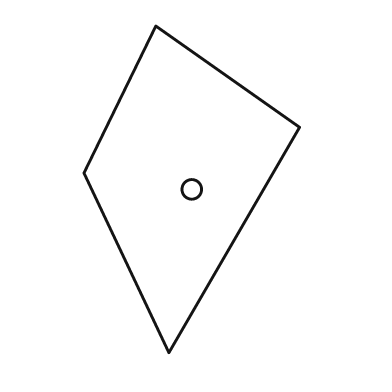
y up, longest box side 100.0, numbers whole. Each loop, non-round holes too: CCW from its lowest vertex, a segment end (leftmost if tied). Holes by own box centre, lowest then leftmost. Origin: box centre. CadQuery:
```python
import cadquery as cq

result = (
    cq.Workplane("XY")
    .moveTo(-7.0, -50.0)
    .lineTo(33.0, 19.0)
    .lineTo(-11.0, 50.0)
    .lineTo(-33.0, 5.0)
    .close()
    .moveTo(0.0, 0.0)
    .circle(3.0)
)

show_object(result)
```